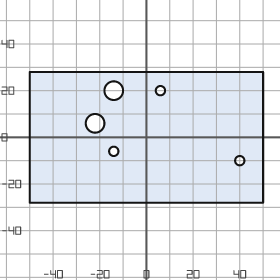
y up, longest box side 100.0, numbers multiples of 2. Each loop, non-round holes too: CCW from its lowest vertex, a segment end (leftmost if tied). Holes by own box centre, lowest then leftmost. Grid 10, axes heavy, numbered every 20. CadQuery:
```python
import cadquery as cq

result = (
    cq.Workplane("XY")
    .moveTo(-50.0, -28.0)
    .lineTo(50.0, -28.0)
    .lineTo(50.0, 28.0)
    .lineTo(-50.0, 28.0)
    .close()
    .moveTo(40.0, -10.0)
    .circle(2.0)
    .moveTo(-14.0, -6.0)
    .circle(2.0)
    .moveTo(-22.0, 6.0)
    .circle(4.0)
    .moveTo(-14.0, 20.0)
    .circle(4.0)
    .moveTo(6.0, 20.0)
    .circle(2.0)
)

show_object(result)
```